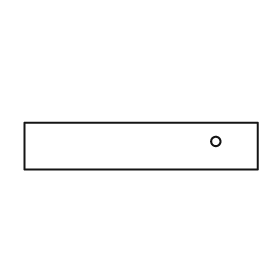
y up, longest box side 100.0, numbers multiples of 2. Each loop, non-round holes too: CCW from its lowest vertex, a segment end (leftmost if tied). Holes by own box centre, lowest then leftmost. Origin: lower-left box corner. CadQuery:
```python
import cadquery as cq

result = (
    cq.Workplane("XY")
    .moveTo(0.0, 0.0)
    .lineTo(100.0, 0.0)
    .lineTo(100.0, 20.0)
    .lineTo(0.0, 20.0)
    .close()
    .moveTo(82.0, 12.0)
    .circle(2.0)
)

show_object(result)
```